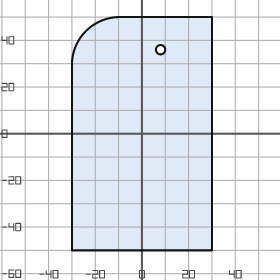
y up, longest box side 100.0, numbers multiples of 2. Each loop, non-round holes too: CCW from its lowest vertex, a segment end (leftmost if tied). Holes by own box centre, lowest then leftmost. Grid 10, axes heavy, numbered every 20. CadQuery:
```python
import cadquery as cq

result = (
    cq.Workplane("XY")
    .moveTo(-30.0, -50.0)
    .lineTo(30.0, -50.0)
    .lineTo(30.0, 50.0)
    .lineTo(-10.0, 50.0)
    .threePointArc((-24.0, 44.0), (-30.0, 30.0))
    .close()
    .moveTo(8.0, 36.0)
    .circle(2.0)
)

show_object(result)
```